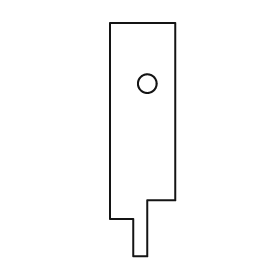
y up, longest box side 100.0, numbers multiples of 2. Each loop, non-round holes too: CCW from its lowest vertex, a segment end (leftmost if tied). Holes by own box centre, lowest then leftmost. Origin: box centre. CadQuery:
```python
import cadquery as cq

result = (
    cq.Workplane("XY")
    .moveTo(-4.0, -50.0)
    .lineTo(2.0, -50.0)
    .lineTo(2.0, -26.0)
    .lineTo(14.0, -26.0)
    .lineTo(14.0, 50.0)
    .lineTo(-14.0, 50.0)
    .lineTo(-14.0, -34.0)
    .lineTo(-4.0, -34.0)
    .close()
    .moveTo(2.0, 24.0)
    .circle(4.0)
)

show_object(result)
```